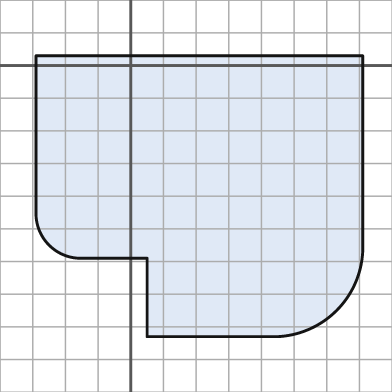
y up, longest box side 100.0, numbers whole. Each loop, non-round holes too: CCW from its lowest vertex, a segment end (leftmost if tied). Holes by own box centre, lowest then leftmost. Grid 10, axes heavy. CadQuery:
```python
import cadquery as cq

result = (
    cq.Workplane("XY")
    .moveTo(5.0, -83.0)
    .lineTo(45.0, -83.0)
    .threePointArc((63.0, -75.0), (71.0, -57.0))
    .lineTo(71.0, 3.0)
    .lineTo(-29.0, 3.0)
    .lineTo(-29.0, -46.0)
    .threePointArc((-25.0, -55.0), (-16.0, -59.0))
    .lineTo(5.0, -59.0)
    .close()
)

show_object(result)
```